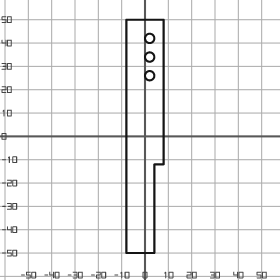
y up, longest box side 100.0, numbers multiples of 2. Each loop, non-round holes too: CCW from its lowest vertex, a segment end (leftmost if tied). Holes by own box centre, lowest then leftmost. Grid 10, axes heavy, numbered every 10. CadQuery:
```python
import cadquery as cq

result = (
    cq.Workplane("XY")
    .moveTo(-8.0, -50.0)
    .lineTo(4.0, -50.0)
    .lineTo(4.0, -12.0)
    .lineTo(8.0, -12.0)
    .lineTo(8.0, 50.0)
    .lineTo(-8.0, 50.0)
    .close()
    .moveTo(2.0, 26.0)
    .circle(2.0)
    .moveTo(2.0, 34.0)
    .circle(2.0)
    .moveTo(2.0, 42.0)
    .circle(2.0)
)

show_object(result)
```